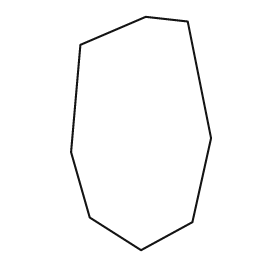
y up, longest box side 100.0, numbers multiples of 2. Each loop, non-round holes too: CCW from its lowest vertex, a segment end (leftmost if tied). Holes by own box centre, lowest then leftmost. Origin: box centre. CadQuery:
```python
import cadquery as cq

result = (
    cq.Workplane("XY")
    .moveTo(0.0, -50.0)
    .lineTo(22.0, -38.0)
    .lineTo(30.0, -2.0)
    .lineTo(20.0, 48.0)
    .lineTo(2.0, 50.0)
    .lineTo(-26.0, 38.0)
    .lineTo(-30.0, -8.0)
    .lineTo(-22.0, -36.0)
    .close()
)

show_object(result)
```